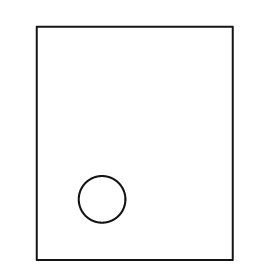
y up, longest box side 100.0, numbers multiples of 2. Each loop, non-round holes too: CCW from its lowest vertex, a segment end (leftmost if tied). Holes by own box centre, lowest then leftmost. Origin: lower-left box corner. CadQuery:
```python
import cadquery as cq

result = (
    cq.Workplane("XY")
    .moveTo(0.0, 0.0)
    .lineTo(84.0, 0.0)
    .lineTo(84.0, 100.0)
    .lineTo(0.0, 100.0)
    .close()
    .moveTo(28.0, 26.0)
    .circle(10.0)
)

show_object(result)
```